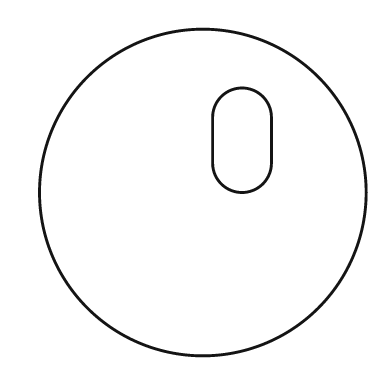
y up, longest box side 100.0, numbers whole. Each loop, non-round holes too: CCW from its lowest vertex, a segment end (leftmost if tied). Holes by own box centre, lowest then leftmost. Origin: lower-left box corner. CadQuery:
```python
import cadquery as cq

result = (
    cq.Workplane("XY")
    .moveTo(50.0, 50.0)
    .circle(50.0)
    .moveTo(53.0, 59.0)
    .threePointArc((62.0, 50.0), (71.0, 59.0))
    .lineTo(71.0, 73.0)
    .threePointArc((62.0, 82.0), (53.0, 73.0))
    .close()
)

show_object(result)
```